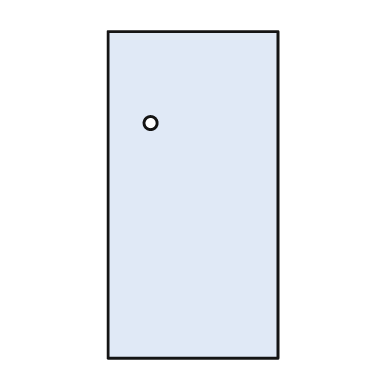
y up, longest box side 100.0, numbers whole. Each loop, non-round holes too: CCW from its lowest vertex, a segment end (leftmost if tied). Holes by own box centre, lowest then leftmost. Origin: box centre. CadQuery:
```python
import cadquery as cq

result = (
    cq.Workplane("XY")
    .moveTo(-26.0, -50.0)
    .lineTo(26.0, -50.0)
    .lineTo(26.0, 50.0)
    .lineTo(-26.0, 50.0)
    .close()
    .moveTo(-13.0, 22.0)
    .circle(2.0)
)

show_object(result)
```